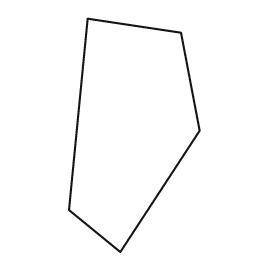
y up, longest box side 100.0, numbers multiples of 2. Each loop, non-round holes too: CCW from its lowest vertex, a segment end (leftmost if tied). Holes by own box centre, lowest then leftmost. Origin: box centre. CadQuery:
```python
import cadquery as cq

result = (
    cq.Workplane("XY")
    .moveTo(-6.0, -50.0)
    .lineTo(28.0, 2.0)
    .lineTo(20.0, 44.0)
    .lineTo(-20.0, 50.0)
    .lineTo(-28.0, -32.0)
    .close()
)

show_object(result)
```